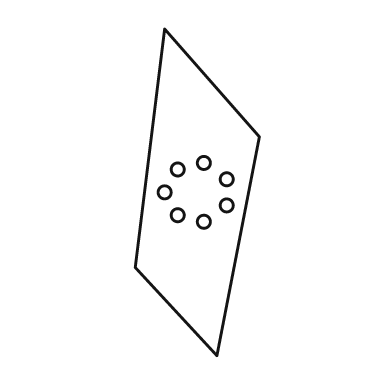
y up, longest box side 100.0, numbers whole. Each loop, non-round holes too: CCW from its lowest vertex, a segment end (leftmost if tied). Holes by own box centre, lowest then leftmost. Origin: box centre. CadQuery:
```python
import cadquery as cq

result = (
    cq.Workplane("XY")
    .moveTo(6.0, -50.0)
    .lineTo(19.0, 17.0)
    .lineTo(-10.0, 50.0)
    .lineTo(-19.0, -23.0)
    .close()
    .moveTo(2.0, -9.0)
    .circle(2.0)
    .moveTo(-6.0, -7.0)
    .circle(2.0)
    .moveTo(9.0, -4.0)
    .circle(2.0)
    .moveTo(-10.0, 0.0)
    .circle(2.0)
    .moveTo(9.0, 4.0)
    .circle(2.0)
    .moveTo(-6.0, 7.0)
    .circle(2.0)
    .moveTo(2.0, 9.0)
    .circle(2.0)
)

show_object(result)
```